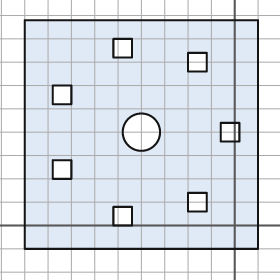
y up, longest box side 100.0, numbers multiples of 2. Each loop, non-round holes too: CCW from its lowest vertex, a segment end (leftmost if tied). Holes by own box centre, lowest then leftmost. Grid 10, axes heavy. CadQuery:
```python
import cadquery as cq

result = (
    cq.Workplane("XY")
    .moveTo(-90.0, -10.0)
    .lineTo(10.0, -10.0)
    .lineTo(10.0, 88.0)
    .lineTo(-90.0, 88.0)
    .close()
    .moveTo(-52.0, 0.0)
    .lineTo(-44.0, 0.0)
    .lineTo(-44.0, 8.0)
    .lineTo(-52.0, 8.0)
    .close()
    .moveTo(-20.0, 6.0)
    .lineTo(-12.0, 6.0)
    .lineTo(-12.0, 14.0)
    .lineTo(-20.0, 14.0)
    .close()
    .moveTo(-78.0, 20.0)
    .lineTo(-70.0, 20.0)
    .lineTo(-70.0, 28.0)
    .lineTo(-78.0, 28.0)
    .close()
    .moveTo(-40.0, 40.0)
    .circle(8.0)
    .moveTo(-6.0, 36.0)
    .lineTo(2.0, 36.0)
    .lineTo(2.0, 44.0)
    .lineTo(-6.0, 44.0)
    .close()
    .moveTo(-78.0, 52.0)
    .lineTo(-70.0, 52.0)
    .lineTo(-70.0, 60.0)
    .lineTo(-78.0, 60.0)
    .close()
    .moveTo(-20.0, 66.0)
    .lineTo(-12.0, 66.0)
    .lineTo(-12.0, 74.0)
    .lineTo(-20.0, 74.0)
    .close()
    .moveTo(-52.0, 72.0)
    .lineTo(-44.0, 72.0)
    .lineTo(-44.0, 80.0)
    .lineTo(-52.0, 80.0)
    .close()
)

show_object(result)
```